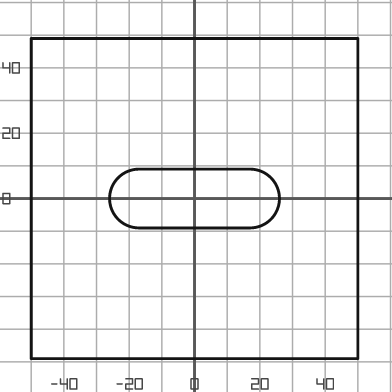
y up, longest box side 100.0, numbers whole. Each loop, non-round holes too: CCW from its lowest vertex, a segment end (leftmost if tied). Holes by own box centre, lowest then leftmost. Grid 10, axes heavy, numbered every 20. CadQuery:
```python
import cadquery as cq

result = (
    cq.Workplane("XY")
    .moveTo(-50.0, -49.0)
    .lineTo(50.0, -49.0)
    .lineTo(50.0, 49.0)
    .lineTo(-50.0, 49.0)
    .close()
    .moveTo(-17.0, -9.0)
    .lineTo(17.0, -9.0)
    .threePointArc((26.0, 0.0), (17.0, 9.0))
    .lineTo(-17.0, 9.0)
    .threePointArc((-26.0, 0.0), (-17.0, -9.0))
    .close()
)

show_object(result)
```